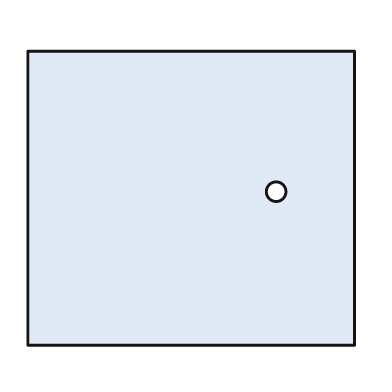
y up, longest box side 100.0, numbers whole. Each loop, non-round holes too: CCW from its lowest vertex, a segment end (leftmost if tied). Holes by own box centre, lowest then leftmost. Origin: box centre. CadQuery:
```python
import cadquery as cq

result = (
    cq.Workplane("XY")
    .moveTo(-50.0, -45.0)
    .lineTo(50.0, -45.0)
    .lineTo(50.0, 45.0)
    .lineTo(-50.0, 45.0)
    .close()
    .moveTo(26.0, 2.0)
    .circle(3.0)
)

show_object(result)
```